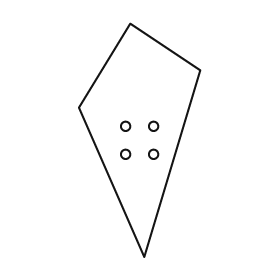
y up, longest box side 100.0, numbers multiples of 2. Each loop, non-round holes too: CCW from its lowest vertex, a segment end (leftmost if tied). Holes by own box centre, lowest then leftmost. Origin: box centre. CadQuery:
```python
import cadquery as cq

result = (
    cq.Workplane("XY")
    .moveTo(2.0, -50.0)
    .lineTo(26.0, 30.0)
    .lineTo(-4.0, 50.0)
    .lineTo(-26.0, 14.0)
    .close()
    .moveTo(-6.0, -6.0)
    .circle(2.0)
    .moveTo(6.0, -6.0)
    .circle(2.0)
    .moveTo(-6.0, 6.0)
    .circle(2.0)
    .moveTo(6.0, 6.0)
    .circle(2.0)
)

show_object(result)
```